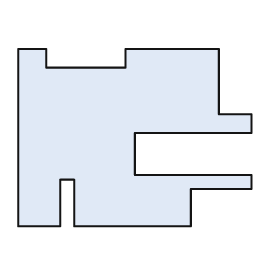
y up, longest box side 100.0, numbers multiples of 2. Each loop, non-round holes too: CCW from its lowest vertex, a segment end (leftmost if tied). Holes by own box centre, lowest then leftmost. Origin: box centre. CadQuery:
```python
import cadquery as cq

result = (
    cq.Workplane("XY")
    .moveTo(-50.0, -38.0)
    .lineTo(-32.0, -38.0)
    .lineTo(-32.0, -18.0)
    .lineTo(-26.0, -18.0)
    .lineTo(-26.0, -38.0)
    .lineTo(24.0, -38.0)
    .lineTo(24.0, -22.0)
    .lineTo(50.0, -22.0)
    .lineTo(50.0, -16.0)
    .lineTo(0.0, -16.0)
    .lineTo(0.0, 2.0)
    .lineTo(50.0, 2.0)
    .lineTo(50.0, 10.0)
    .lineTo(36.0, 10.0)
    .lineTo(36.0, 38.0)
    .lineTo(-4.0, 38.0)
    .lineTo(-4.0, 30.0)
    .lineTo(-38.0, 30.0)
    .lineTo(-38.0, 38.0)
    .lineTo(-50.0, 38.0)
    .close()
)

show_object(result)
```